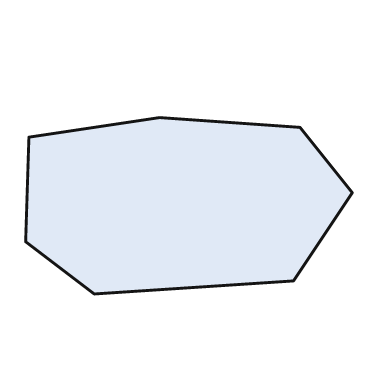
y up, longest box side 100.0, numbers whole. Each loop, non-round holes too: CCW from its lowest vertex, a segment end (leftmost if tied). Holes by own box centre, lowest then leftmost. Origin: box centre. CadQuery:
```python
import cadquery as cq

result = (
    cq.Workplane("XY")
    .moveTo(-29.0, -27.0)
    .lineTo(32.0, -23.0)
    .lineTo(50.0, 4.0)
    .lineTo(34.0, 24.0)
    .lineTo(-9.0, 27.0)
    .lineTo(-49.0, 21.0)
    .lineTo(-50.0, -11.0)
    .close()
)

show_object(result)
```